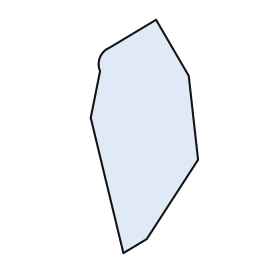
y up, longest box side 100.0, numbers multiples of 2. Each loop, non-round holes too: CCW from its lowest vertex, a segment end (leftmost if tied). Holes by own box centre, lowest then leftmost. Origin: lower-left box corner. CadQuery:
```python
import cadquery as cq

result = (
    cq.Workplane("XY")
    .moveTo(14.0, 0.0)
    .lineTo(24.0, 6.0)
    .lineTo(46.0, 40.0)
    .lineTo(42.0, 76.0)
    .lineTo(28.0, 100.0)
    .lineTo(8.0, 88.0)
    .threePointArc((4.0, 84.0), (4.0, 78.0))
    .lineTo(0.0, 58.0)
    .close()
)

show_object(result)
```